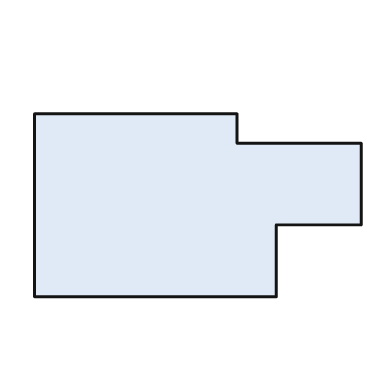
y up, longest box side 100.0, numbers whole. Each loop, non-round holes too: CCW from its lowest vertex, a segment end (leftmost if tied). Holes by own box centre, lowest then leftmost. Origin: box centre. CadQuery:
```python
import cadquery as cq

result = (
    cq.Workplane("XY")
    .moveTo(-50.0, -28.0)
    .lineTo(24.0, -28.0)
    .lineTo(24.0, -6.0)
    .lineTo(50.0, -6.0)
    .lineTo(50.0, 19.0)
    .lineTo(12.0, 19.0)
    .lineTo(12.0, 28.0)
    .lineTo(-50.0, 28.0)
    .close()
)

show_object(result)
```